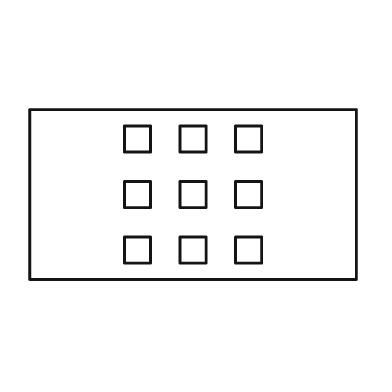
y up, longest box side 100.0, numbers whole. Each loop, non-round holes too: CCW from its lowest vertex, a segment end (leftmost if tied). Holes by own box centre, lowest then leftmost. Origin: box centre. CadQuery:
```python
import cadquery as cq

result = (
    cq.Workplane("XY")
    .moveTo(-50.0, -26.0)
    .lineTo(50.0, -26.0)
    .lineTo(50.0, 26.0)
    .lineTo(-50.0, 26.0)
    .close()
    .moveTo(-21.0, -21.0)
    .lineTo(-13.0, -21.0)
    .lineTo(-13.0, -13.0)
    .lineTo(-21.0, -13.0)
    .close()
    .moveTo(-4.0, -21.0)
    .lineTo(4.0, -21.0)
    .lineTo(4.0, -13.0)
    .lineTo(-4.0, -13.0)
    .close()
    .moveTo(13.0, -21.0)
    .lineTo(21.0, -21.0)
    .lineTo(21.0, -13.0)
    .lineTo(13.0, -13.0)
    .close()
    .moveTo(-21.0, -4.0)
    .lineTo(-13.0, -4.0)
    .lineTo(-13.0, 4.0)
    .lineTo(-21.0, 4.0)
    .close()
    .moveTo(-4.0, -4.0)
    .lineTo(4.0, -4.0)
    .lineTo(4.0, 4.0)
    .lineTo(-4.0, 4.0)
    .close()
    .moveTo(13.0, -4.0)
    .lineTo(21.0, -4.0)
    .lineTo(21.0, 4.0)
    .lineTo(13.0, 4.0)
    .close()
    .moveTo(-21.0, 13.0)
    .lineTo(-13.0, 13.0)
    .lineTo(-13.0, 21.0)
    .lineTo(-21.0, 21.0)
    .close()
    .moveTo(-4.0, 13.0)
    .lineTo(4.0, 13.0)
    .lineTo(4.0, 21.0)
    .lineTo(-4.0, 21.0)
    .close()
    .moveTo(13.0, 13.0)
    .lineTo(21.0, 13.0)
    .lineTo(21.0, 21.0)
    .lineTo(13.0, 21.0)
    .close()
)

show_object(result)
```